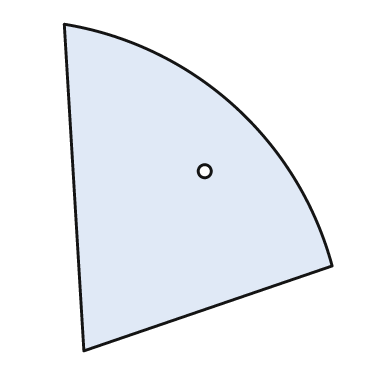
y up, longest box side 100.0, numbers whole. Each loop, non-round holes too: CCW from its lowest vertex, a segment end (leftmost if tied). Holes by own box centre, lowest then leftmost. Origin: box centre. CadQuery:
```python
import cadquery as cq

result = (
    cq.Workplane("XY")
    .moveTo(-35.0, -50.0)
    .lineTo(41.0, -24.0)
    .threePointArc((11.0, 25.0), (-41.0, 50.0))
    .close()
    .moveTo(2.0, 5.0)
    .circle(2.0)
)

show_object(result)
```